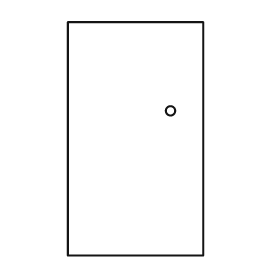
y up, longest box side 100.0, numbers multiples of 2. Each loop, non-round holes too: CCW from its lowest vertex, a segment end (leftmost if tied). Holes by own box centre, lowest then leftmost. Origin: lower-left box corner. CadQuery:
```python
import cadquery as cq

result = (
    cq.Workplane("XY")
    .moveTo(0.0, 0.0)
    .lineTo(58.0, 0.0)
    .lineTo(58.0, 100.0)
    .lineTo(0.0, 100.0)
    .close()
    .moveTo(44.0, 62.0)
    .circle(2.0)
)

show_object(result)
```